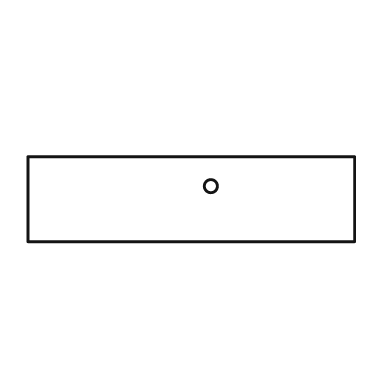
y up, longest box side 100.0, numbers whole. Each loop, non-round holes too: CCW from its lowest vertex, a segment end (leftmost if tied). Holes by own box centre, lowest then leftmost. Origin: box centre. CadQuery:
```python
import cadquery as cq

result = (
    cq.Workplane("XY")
    .moveTo(-50.0, -13.0)
    .lineTo(50.0, -13.0)
    .lineTo(50.0, 13.0)
    .lineTo(-50.0, 13.0)
    .close()
    .moveTo(6.0, 4.0)
    .circle(2.0)
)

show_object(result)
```